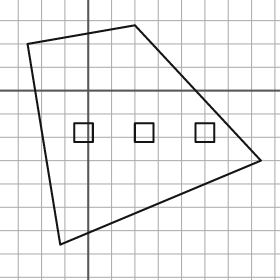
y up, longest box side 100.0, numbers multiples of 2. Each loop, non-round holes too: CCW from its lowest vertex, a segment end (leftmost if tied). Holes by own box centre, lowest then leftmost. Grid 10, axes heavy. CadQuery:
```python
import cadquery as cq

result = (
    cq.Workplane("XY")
    .moveTo(-12.0, -66.0)
    .lineTo(74.0, -30.0)
    .lineTo(20.0, 28.0)
    .lineTo(-26.0, 20.0)
    .close()
    .moveTo(-6.0, -22.0)
    .lineTo(2.0, -22.0)
    .lineTo(2.0, -14.0)
    .lineTo(-6.0, -14.0)
    .close()
    .moveTo(20.0, -22.0)
    .lineTo(28.0, -22.0)
    .lineTo(28.0, -14.0)
    .lineTo(20.0, -14.0)
    .close()
    .moveTo(46.0, -22.0)
    .lineTo(54.0, -22.0)
    .lineTo(54.0, -14.0)
    .lineTo(46.0, -14.0)
    .close()
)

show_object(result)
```